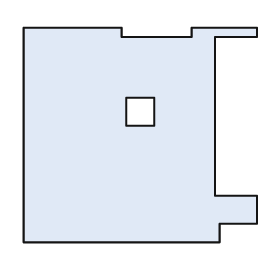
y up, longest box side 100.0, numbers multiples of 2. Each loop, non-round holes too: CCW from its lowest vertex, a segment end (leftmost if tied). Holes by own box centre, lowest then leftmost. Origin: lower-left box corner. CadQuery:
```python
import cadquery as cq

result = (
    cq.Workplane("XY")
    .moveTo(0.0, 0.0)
    .lineTo(84.0, 0.0)
    .lineTo(84.0, 8.0)
    .lineTo(100.0, 8.0)
    .lineTo(100.0, 20.0)
    .lineTo(82.0, 20.0)
    .lineTo(82.0, 88.0)
    .lineTo(100.0, 88.0)
    .lineTo(100.0, 92.0)
    .lineTo(72.0, 92.0)
    .lineTo(72.0, 88.0)
    .lineTo(42.0, 88.0)
    .lineTo(42.0, 92.0)
    .lineTo(0.0, 92.0)
    .close()
    .moveTo(44.0, 50.0)
    .lineTo(56.0, 50.0)
    .lineTo(56.0, 62.0)
    .lineTo(44.0, 62.0)
    .close()
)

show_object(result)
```